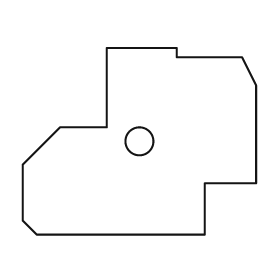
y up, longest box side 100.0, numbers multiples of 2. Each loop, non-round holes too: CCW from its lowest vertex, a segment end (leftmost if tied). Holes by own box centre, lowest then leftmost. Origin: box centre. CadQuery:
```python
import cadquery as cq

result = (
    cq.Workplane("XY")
    .moveTo(-44.0, -40.0)
    .lineTo(28.0, -40.0)
    .lineTo(28.0, -18.0)
    .lineTo(50.0, -18.0)
    .lineTo(50.0, 24.0)
    .lineTo(44.0, 36.0)
    .lineTo(16.0, 36.0)
    .lineTo(16.0, 40.0)
    .lineTo(-14.0, 40.0)
    .lineTo(-14.0, 6.0)
    .lineTo(-34.0, 6.0)
    .lineTo(-50.0, -10.0)
    .lineTo(-50.0, -34.0)
    .close()
    .moveTo(0.0, 0.0)
    .circle(6.0)
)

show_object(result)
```